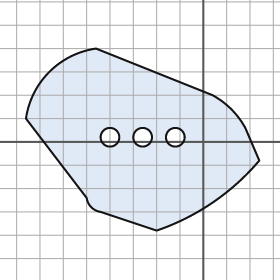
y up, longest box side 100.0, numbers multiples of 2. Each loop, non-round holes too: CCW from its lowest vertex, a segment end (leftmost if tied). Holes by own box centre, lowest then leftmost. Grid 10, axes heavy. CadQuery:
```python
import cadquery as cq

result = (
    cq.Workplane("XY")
    .moveTo(-20.0, -38.0)
    .threePointArc((4.0, -26.0), (24.0, -8.0))
    .lineTo(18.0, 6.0)
    .threePointArc((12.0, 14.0), (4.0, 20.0))
    .lineTo(-46.0, 40.0)
    .threePointArc((-66.0, 30.0), (-76.0, 10.0))
    .lineTo(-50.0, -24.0)
    .threePointArc((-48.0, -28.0), (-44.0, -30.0))
    .close()
    .moveTo(-40.0, 2.0)
    .circle(4.0)
    .moveTo(-26.0, 2.0)
    .circle(4.0)
    .moveTo(-12.0, 2.0)
    .circle(4.0)
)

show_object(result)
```